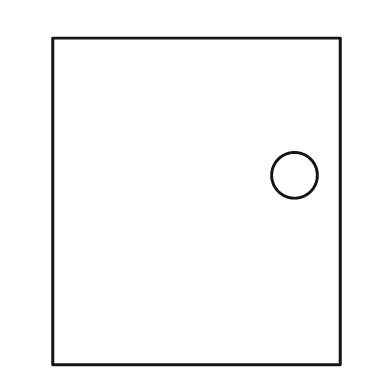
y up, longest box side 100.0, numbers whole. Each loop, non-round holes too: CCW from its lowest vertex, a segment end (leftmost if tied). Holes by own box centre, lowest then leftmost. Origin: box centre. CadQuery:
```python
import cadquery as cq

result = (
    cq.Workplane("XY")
    .moveTo(-44.0, -50.0)
    .lineTo(44.0, -50.0)
    .lineTo(44.0, 50.0)
    .lineTo(-44.0, 50.0)
    .close()
    .moveTo(30.0, 8.0)
    .circle(7.0)
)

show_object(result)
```